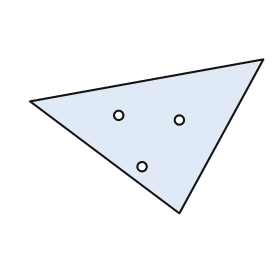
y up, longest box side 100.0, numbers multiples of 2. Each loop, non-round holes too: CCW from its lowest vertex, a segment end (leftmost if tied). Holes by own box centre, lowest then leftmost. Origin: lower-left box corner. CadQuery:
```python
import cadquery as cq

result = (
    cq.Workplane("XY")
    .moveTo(64.0, 0.0)
    .lineTo(100.0, 66.0)
    .lineTo(0.0, 48.0)
    .close()
    .moveTo(48.0, 20.0)
    .circle(2.0)
    .moveTo(64.0, 40.0)
    .circle(2.0)
    .moveTo(38.0, 42.0)
    .circle(2.0)
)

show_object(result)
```